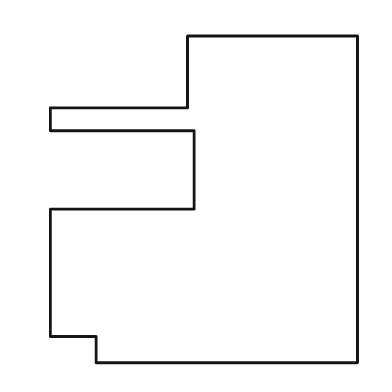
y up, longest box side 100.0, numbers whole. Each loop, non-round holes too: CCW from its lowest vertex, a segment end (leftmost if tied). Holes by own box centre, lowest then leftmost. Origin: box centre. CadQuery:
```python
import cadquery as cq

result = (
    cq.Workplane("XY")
    .moveTo(-33.0, -50.0)
    .lineTo(47.0, -50.0)
    .lineTo(47.0, 50.0)
    .lineTo(-5.0, 50.0)
    .lineTo(-5.0, 28.0)
    .lineTo(-47.0, 28.0)
    .lineTo(-47.0, 21.0)
    .lineTo(-3.0, 21.0)
    .lineTo(-3.0, -3.0)
    .lineTo(-47.0, -3.0)
    .lineTo(-47.0, -42.0)
    .lineTo(-33.0, -42.0)
    .close()
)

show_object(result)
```